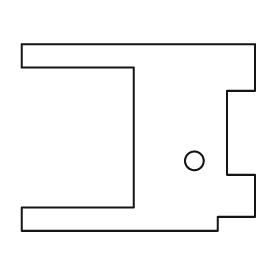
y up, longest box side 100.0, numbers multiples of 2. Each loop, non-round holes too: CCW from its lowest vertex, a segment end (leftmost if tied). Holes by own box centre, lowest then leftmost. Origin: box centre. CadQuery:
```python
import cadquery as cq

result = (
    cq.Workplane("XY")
    .moveTo(-50.0, -40.0)
    .lineTo(34.0, -40.0)
    .lineTo(34.0, -34.0)
    .lineTo(50.0, -34.0)
    .lineTo(50.0, -16.0)
    .lineTo(38.0, -16.0)
    .lineTo(38.0, 20.0)
    .lineTo(50.0, 20.0)
    .lineTo(50.0, 40.0)
    .lineTo(-50.0, 40.0)
    .lineTo(-50.0, 30.0)
    .lineTo(-2.0, 30.0)
    .lineTo(-2.0, -30.0)
    .lineTo(-50.0, -30.0)
    .close()
    .moveTo(24.0, -10.0)
    .circle(4.0)
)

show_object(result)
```